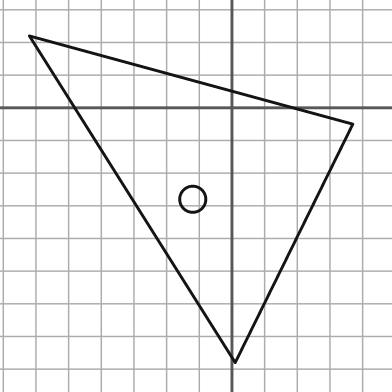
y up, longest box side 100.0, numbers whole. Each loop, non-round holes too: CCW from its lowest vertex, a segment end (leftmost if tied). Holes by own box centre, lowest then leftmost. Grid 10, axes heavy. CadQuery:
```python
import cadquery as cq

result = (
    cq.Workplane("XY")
    .moveTo(1.0, -78.0)
    .lineTo(37.0, -5.0)
    .lineTo(-62.0, 22.0)
    .close()
    .moveTo(-12.0, -28.0)
    .circle(4.0)
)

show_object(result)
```